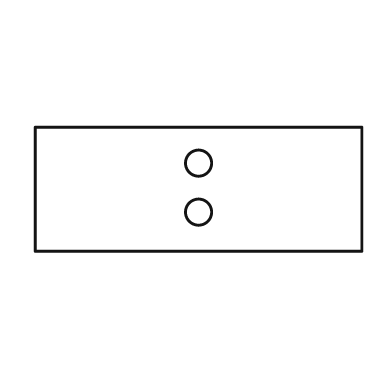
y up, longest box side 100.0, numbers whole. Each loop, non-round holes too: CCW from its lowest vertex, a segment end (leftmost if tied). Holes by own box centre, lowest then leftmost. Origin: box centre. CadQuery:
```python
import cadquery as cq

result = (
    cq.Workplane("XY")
    .moveTo(-50.0, -19.0)
    .lineTo(50.0, -19.0)
    .lineTo(50.0, 19.0)
    .lineTo(-50.0, 19.0)
    .close()
    .moveTo(0.0, -7.0)
    .circle(4.0)
    .moveTo(0.0, 8.0)
    .circle(4.0)
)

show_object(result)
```